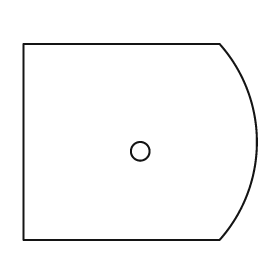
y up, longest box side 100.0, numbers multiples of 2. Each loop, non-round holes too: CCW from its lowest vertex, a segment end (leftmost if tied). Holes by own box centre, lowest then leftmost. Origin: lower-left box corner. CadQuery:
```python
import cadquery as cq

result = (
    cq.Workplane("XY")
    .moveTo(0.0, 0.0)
    .lineTo(84.0, 0.0)
    .threePointArc((100.0, 42.0), (84.0, 84.0))
    .lineTo(0.0, 84.0)
    .close()
    .moveTo(50.0, 38.0)
    .circle(4.0)
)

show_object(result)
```